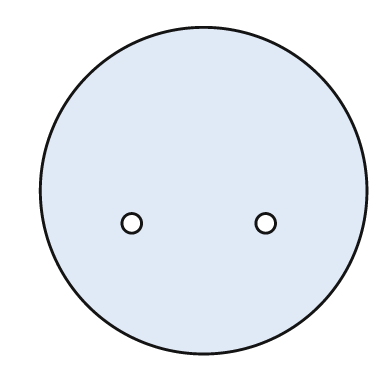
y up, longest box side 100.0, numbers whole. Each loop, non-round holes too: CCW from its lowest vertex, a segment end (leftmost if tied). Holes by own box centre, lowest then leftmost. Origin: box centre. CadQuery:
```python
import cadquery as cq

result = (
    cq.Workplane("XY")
    .moveTo(0.0, 0.0)
    .circle(50.0)
    .moveTo(-22.0, -10.0)
    .circle(3.0)
    .moveTo(19.0, -10.0)
    .circle(3.0)
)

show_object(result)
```